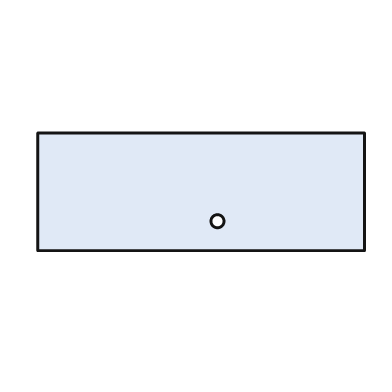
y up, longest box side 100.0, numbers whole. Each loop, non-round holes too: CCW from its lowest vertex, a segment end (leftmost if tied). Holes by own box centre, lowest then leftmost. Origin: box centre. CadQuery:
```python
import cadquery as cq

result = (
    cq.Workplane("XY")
    .moveTo(-50.0, -18.0)
    .lineTo(50.0, -18.0)
    .lineTo(50.0, 18.0)
    .lineTo(-50.0, 18.0)
    .close()
    .moveTo(5.0, -9.0)
    .circle(2.0)
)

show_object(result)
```